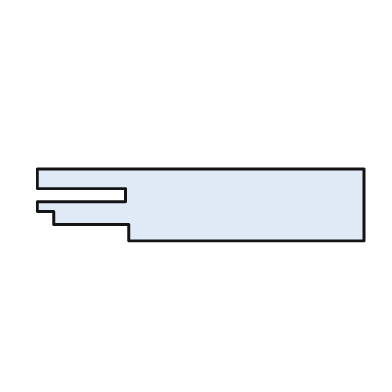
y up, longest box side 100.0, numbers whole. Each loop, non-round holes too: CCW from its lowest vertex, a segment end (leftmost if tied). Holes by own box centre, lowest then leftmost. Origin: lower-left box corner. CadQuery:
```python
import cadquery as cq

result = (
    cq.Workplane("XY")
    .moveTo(28.0, 0.0)
    .lineTo(100.0, 0.0)
    .lineTo(100.0, 22.0)
    .lineTo(0.0, 22.0)
    .lineTo(0.0, 16.0)
    .lineTo(27.0, 16.0)
    .lineTo(27.0, 12.0)
    .lineTo(0.0, 12.0)
    .lineTo(0.0, 9.0)
    .lineTo(5.0, 9.0)
    .lineTo(5.0, 5.0)
    .lineTo(28.0, 5.0)
    .close()
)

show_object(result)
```